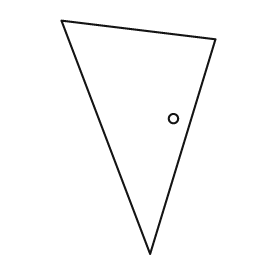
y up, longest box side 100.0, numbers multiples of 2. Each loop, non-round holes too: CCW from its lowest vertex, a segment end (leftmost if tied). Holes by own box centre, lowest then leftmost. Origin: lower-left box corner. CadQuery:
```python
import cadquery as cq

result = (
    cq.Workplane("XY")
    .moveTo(38.0, 0.0)
    .lineTo(66.0, 92.0)
    .lineTo(0.0, 100.0)
    .close()
    .moveTo(48.0, 58.0)
    .circle(2.0)
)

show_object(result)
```